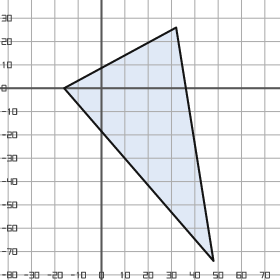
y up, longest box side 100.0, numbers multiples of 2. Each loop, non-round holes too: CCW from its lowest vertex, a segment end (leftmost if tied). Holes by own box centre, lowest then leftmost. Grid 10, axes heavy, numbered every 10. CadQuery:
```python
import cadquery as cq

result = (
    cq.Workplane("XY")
    .moveTo(48.0, -74.0)
    .lineTo(32.0, 26.0)
    .lineTo(-16.0, 0.0)
    .close()
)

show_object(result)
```